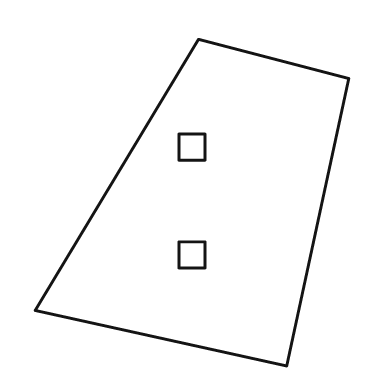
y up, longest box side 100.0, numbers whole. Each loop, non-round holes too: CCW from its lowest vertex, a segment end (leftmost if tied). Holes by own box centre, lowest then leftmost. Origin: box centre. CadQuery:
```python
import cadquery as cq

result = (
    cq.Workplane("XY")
    .moveTo(29.0, -50.0)
    .lineTo(48.0, 38.0)
    .lineTo(2.0, 50.0)
    .lineTo(-48.0, -33.0)
    .close()
    .moveTo(-4.0, -20.0)
    .lineTo(4.0, -20.0)
    .lineTo(4.0, -12.0)
    .lineTo(-4.0, -12.0)
    .close()
    .moveTo(-4.0, 13.0)
    .lineTo(4.0, 13.0)
    .lineTo(4.0, 21.0)
    .lineTo(-4.0, 21.0)
    .close()
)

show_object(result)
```